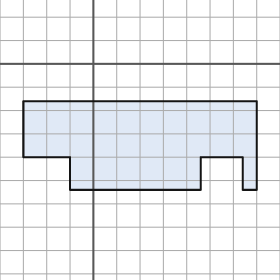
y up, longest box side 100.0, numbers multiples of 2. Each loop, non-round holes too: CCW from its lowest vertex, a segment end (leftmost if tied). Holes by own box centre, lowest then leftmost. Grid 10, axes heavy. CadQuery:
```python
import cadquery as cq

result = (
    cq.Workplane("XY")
    .moveTo(-10.0, -54.0)
    .lineTo(46.0, -54.0)
    .lineTo(46.0, -40.0)
    .lineTo(64.0, -40.0)
    .lineTo(64.0, -54.0)
    .lineTo(70.0, -54.0)
    .lineTo(70.0, -16.0)
    .lineTo(-30.0, -16.0)
    .lineTo(-30.0, -40.0)
    .lineTo(-10.0, -40.0)
    .close()
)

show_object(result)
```